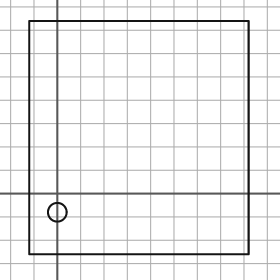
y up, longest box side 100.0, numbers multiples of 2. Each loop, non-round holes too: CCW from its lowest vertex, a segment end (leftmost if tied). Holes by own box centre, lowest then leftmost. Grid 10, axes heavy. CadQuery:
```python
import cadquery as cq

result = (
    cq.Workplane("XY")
    .moveTo(-12.0, -26.0)
    .lineTo(82.0, -26.0)
    .lineTo(82.0, 74.0)
    .lineTo(-12.0, 74.0)
    .close()
    .moveTo(0.0, -8.0)
    .circle(4.0)
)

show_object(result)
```